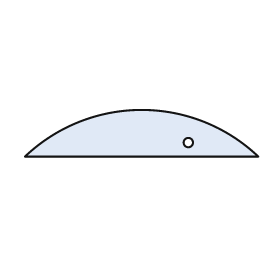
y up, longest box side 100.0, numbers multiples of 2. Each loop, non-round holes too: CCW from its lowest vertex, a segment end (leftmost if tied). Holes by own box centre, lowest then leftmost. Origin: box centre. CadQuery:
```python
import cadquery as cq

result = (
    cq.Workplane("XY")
    .moveTo(-50.0, -10.0)
    .lineTo(50.0, -10.0)
    .threePointArc((0.0, 10.0), (-50.0, -10.0))
    .close()
    .moveTo(20.0, -4.0)
    .circle(2.0)
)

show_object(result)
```